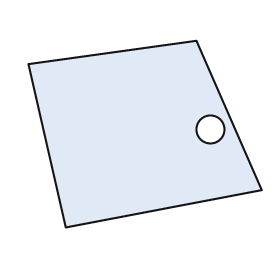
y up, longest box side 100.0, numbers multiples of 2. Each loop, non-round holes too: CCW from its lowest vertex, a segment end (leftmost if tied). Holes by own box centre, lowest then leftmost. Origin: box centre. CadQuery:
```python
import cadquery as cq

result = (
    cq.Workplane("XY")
    .moveTo(-34.0, -40.0)
    .lineTo(50.0, -24.0)
    .lineTo(22.0, 40.0)
    .lineTo(-50.0, 30.0)
    .close()
    .moveTo(28.0, 2.0)
    .circle(6.0)
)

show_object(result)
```